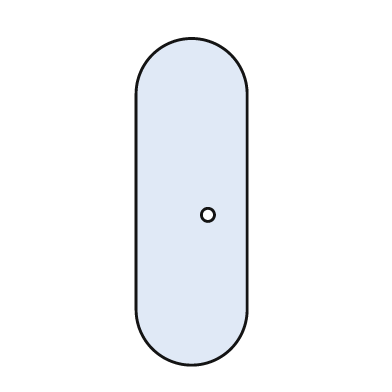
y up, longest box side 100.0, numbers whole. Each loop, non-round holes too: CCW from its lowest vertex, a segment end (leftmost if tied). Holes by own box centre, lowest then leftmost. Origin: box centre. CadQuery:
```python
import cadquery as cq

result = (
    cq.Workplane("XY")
    .moveTo(-17.0, -33.0)
    .threePointArc((0.0, -50.0), (17.0, -33.0))
    .lineTo(17.0, 33.0)
    .threePointArc((0.0, 50.0), (-17.0, 33.0))
    .close()
    .moveTo(5.0, -4.0)
    .circle(2.0)
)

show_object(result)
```